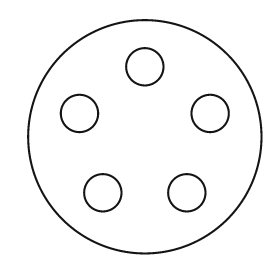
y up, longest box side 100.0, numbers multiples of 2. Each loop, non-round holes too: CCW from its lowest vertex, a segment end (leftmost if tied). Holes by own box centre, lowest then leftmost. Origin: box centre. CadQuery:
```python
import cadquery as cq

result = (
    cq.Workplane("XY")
    .moveTo(0.0, 0.0)
    .circle(50.0)
    .moveTo(-18.0, -24.0)
    .circle(8.0)
    .moveTo(18.0, -24.0)
    .circle(8.0)
    .moveTo(-28.0, 10.0)
    .circle(8.0)
    .moveTo(28.0, 10.0)
    .circle(8.0)
    .moveTo(0.0, 30.0)
    .circle(8.0)
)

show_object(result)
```